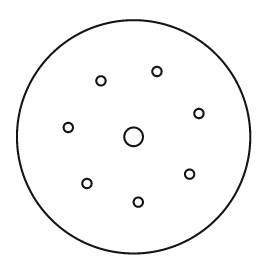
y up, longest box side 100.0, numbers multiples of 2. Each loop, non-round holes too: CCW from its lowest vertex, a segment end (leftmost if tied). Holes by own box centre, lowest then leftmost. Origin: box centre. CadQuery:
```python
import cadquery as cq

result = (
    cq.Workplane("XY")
    .moveTo(0.0, 0.0)
    .circle(50.0)
    .moveTo(2.0, -28.0)
    .circle(2.0)
    .moveTo(-20.0, -20.0)
    .circle(2.0)
    .moveTo(24.0, -16.0)
    .circle(2.0)
    .moveTo(0.0, 0.0)
    .circle(4.0)
    .moveTo(-28.0, 4.0)
    .circle(2.0)
    .moveTo(28.0, 10.0)
    .circle(2.0)
    .moveTo(-14.0, 24.0)
    .circle(2.0)
    .moveTo(10.0, 28.0)
    .circle(2.0)
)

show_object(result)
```